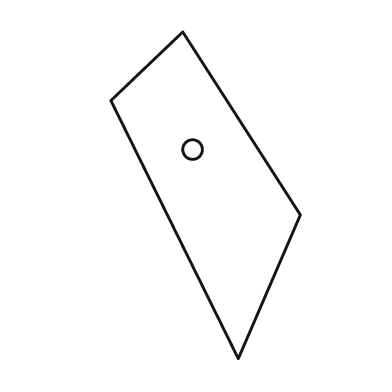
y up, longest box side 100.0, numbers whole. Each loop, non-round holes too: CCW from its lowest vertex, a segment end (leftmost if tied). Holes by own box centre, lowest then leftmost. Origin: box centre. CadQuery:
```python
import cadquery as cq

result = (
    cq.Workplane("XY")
    .moveTo(10.0, -50.0)
    .lineTo(29.0, -6.0)
    .lineTo(-7.0, 50.0)
    .lineTo(-29.0, 29.0)
    .close()
    .moveTo(-4.0, 14.0)
    .circle(3.0)
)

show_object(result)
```